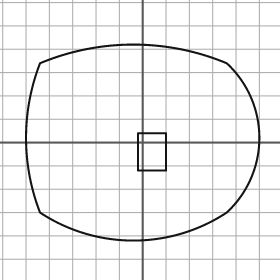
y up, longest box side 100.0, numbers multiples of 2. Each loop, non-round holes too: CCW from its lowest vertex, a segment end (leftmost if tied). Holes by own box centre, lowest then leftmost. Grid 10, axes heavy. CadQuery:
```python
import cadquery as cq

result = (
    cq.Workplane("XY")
    .moveTo(-44.0, -30.0)
    .threePointArc((-4.0, -42.0), (36.0, -30.0))
    .threePointArc((50.0, 2.0), (36.0, 34.0))
    .threePointArc((-4.0, 42.0), (-44.0, 34.0))
    .threePointArc((-50.0, 2.0), (-44.0, -30.0))
    .close()
    .moveTo(-2.0, -12.0)
    .lineTo(10.0, -12.0)
    .lineTo(10.0, 4.0)
    .lineTo(-2.0, 4.0)
    .close()
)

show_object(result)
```